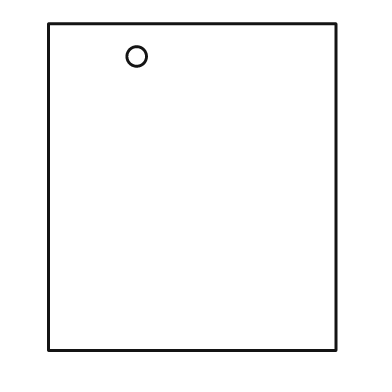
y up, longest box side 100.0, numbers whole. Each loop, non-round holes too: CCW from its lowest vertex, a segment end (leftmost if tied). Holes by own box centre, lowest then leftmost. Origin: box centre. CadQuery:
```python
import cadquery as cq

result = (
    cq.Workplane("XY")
    .moveTo(-44.0, -50.0)
    .lineTo(44.0, -50.0)
    .lineTo(44.0, 50.0)
    .lineTo(-44.0, 50.0)
    .close()
    .moveTo(-17.0, 40.0)
    .circle(3.0)
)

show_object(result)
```